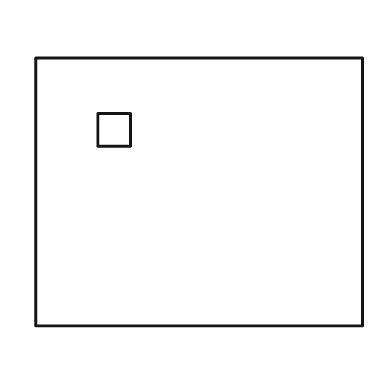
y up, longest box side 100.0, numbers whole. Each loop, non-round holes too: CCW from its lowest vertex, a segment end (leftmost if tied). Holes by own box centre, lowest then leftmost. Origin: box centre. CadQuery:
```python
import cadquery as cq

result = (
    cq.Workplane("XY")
    .moveTo(-50.0, -41.0)
    .lineTo(50.0, -41.0)
    .lineTo(50.0, 41.0)
    .lineTo(-50.0, 41.0)
    .close()
    .moveTo(-31.0, 14.0)
    .lineTo(-21.0, 14.0)
    .lineTo(-21.0, 24.0)
    .lineTo(-31.0, 24.0)
    .close()
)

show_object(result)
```